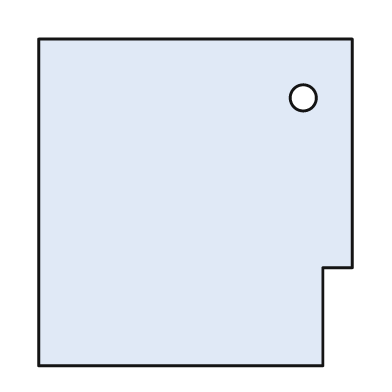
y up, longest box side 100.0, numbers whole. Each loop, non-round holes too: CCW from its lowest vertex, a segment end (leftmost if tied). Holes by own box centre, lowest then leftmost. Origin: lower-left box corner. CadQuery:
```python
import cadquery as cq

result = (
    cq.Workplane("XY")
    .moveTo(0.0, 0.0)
    .lineTo(87.0, 0.0)
    .lineTo(87.0, 30.0)
    .lineTo(96.0, 30.0)
    .lineTo(96.0, 100.0)
    .lineTo(0.0, 100.0)
    .close()
    .moveTo(81.0, 82.0)
    .circle(4.0)
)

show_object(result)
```